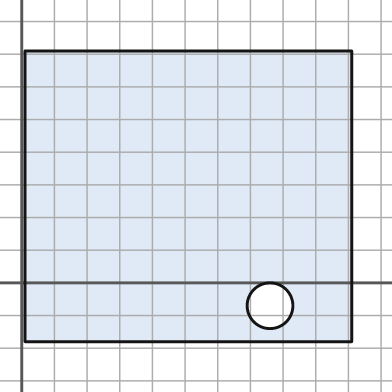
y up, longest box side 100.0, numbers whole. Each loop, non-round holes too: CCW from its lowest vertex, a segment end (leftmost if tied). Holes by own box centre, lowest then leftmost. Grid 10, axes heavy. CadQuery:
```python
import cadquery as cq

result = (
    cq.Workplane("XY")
    .moveTo(1.0, -18.0)
    .lineTo(101.0, -18.0)
    .lineTo(101.0, 71.0)
    .lineTo(1.0, 71.0)
    .close()
    .moveTo(76.0, -7.0)
    .circle(7.0)
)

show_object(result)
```